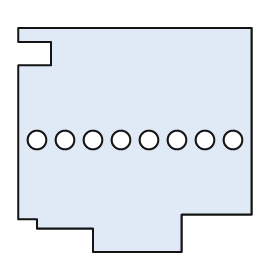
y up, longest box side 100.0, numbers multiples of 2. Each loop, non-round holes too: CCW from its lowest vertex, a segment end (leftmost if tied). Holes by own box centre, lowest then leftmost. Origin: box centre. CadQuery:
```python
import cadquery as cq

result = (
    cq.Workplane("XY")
    .moveTo(-18.0, -48.0)
    .lineTo(20.0, -48.0)
    .lineTo(20.0, -32.0)
    .lineTo(50.0, -32.0)
    .lineTo(50.0, 48.0)
    .lineTo(-50.0, 48.0)
    .lineTo(-50.0, 42.0)
    .lineTo(-36.0, 42.0)
    .lineTo(-36.0, 32.0)
    .lineTo(-50.0, 32.0)
    .lineTo(-50.0, -34.0)
    .lineTo(-42.0, -34.0)
    .lineTo(-42.0, -38.0)
    .lineTo(-18.0, -38.0)
    .close()
    .moveTo(-42.0, 0.0)
    .circle(4.0)
    .moveTo(-30.0, 0.0)
    .circle(4.0)
    .moveTo(-18.0, 0.0)
    .circle(4.0)
    .moveTo(-6.0, 0.0)
    .circle(4.0)
    .moveTo(6.0, 0.0)
    .circle(4.0)
    .moveTo(18.0, 0.0)
    .circle(4.0)
    .moveTo(30.0, 0.0)
    .circle(4.0)
    .moveTo(42.0, 0.0)
    .circle(4.0)
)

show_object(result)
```